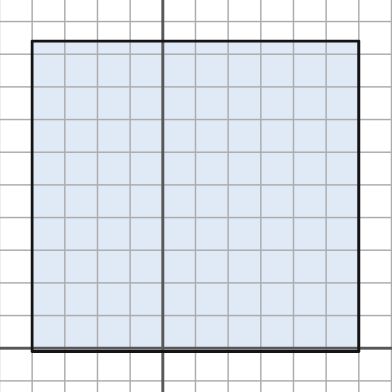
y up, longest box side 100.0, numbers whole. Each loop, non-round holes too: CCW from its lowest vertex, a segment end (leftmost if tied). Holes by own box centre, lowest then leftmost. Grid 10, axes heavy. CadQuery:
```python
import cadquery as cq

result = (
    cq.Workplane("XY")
    .moveTo(-40.0, -1.0)
    .lineTo(60.0, -1.0)
    .lineTo(60.0, 94.0)
    .lineTo(-40.0, 94.0)
    .close()
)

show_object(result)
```